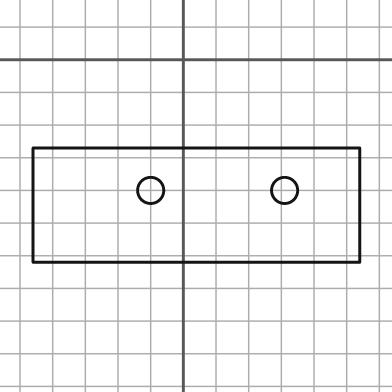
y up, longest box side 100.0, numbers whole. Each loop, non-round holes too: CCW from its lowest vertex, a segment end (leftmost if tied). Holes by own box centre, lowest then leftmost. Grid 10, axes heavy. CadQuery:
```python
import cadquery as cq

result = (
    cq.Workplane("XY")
    .moveTo(-46.0, -62.0)
    .lineTo(54.0, -62.0)
    .lineTo(54.0, -27.0)
    .lineTo(-46.0, -27.0)
    .close()
    .moveTo(-10.0, -40.0)
    .circle(4.0)
    .moveTo(31.0, -40.0)
    .circle(4.0)
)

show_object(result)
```